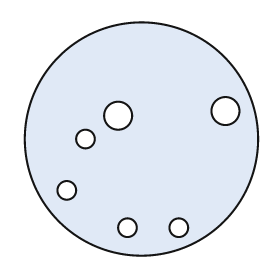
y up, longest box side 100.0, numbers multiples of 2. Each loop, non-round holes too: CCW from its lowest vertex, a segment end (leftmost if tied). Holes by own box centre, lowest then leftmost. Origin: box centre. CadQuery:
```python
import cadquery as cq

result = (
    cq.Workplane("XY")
    .moveTo(0.0, 0.0)
    .circle(50.0)
    .moveTo(-6.0, -38.0)
    .circle(4.0)
    .moveTo(16.0, -38.0)
    .circle(4.0)
    .moveTo(-32.0, -22.0)
    .circle(4.0)
    .moveTo(-24.0, 0.0)
    .circle(4.0)
    .moveTo(-10.0, 10.0)
    .circle(6.0)
    .moveTo(36.0, 12.0)
    .circle(6.0)
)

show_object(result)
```